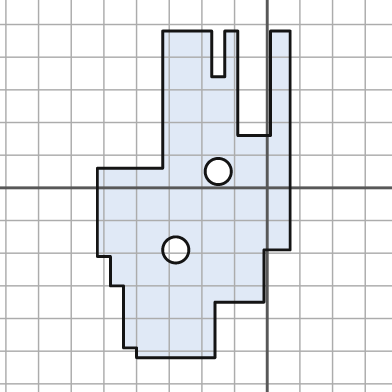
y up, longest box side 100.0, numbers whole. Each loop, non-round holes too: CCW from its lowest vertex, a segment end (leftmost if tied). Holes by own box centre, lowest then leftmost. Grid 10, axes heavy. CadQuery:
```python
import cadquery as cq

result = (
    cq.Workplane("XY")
    .moveTo(-40.0, -52.0)
    .lineTo(-16.0, -52.0)
    .lineTo(-16.0, -35.0)
    .lineTo(-1.0, -35.0)
    .lineTo(-1.0, -19.0)
    .lineTo(7.0, -19.0)
    .lineTo(7.0, 48.0)
    .lineTo(1.0, 48.0)
    .lineTo(1.0, 16.0)
    .lineTo(-9.0, 16.0)
    .lineTo(-9.0, 48.0)
    .lineTo(-13.0, 48.0)
    .lineTo(-13.0, 34.0)
    .lineTo(-17.0, 34.0)
    .lineTo(-17.0, 48.0)
    .lineTo(-32.0, 48.0)
    .lineTo(-32.0, 6.0)
    .lineTo(-52.0, 6.0)
    .lineTo(-52.0, -21.0)
    .lineTo(-48.0, -21.0)
    .lineTo(-48.0, -30.0)
    .lineTo(-44.0, -30.0)
    .lineTo(-44.0, -49.0)
    .lineTo(-40.0, -49.0)
    .close()
    .moveTo(-28.0, -19.0)
    .circle(4.0)
    .moveTo(-15.0, 5.0)
    .circle(4.0)
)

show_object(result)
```